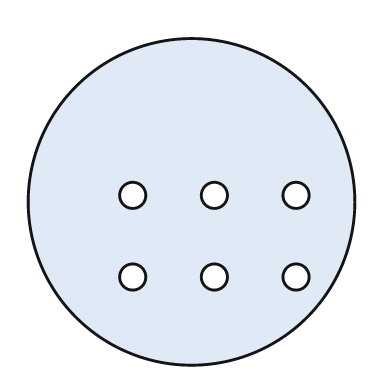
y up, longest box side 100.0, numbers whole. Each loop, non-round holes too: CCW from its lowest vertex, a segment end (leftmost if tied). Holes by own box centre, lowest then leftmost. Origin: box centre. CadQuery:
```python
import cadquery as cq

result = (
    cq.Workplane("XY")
    .moveTo(0.0, 0.0)
    .circle(50.0)
    .moveTo(-18.0, -23.0)
    .circle(4.0)
    .moveTo(7.0, -23.0)
    .circle(4.0)
    .moveTo(32.0, -23.0)
    .circle(4.0)
    .moveTo(-18.0, 2.0)
    .circle(4.0)
    .moveTo(7.0, 2.0)
    .circle(4.0)
    .moveTo(32.0, 2.0)
    .circle(4.0)
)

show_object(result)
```